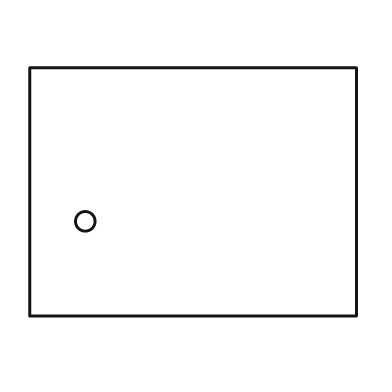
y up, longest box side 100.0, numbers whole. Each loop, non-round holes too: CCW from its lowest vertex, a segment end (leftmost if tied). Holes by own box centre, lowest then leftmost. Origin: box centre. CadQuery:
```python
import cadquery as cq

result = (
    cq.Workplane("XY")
    .moveTo(-50.0, -38.0)
    .lineTo(50.0, -38.0)
    .lineTo(50.0, 38.0)
    .lineTo(-50.0, 38.0)
    .close()
    .moveTo(-33.0, -9.0)
    .circle(3.0)
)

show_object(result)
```